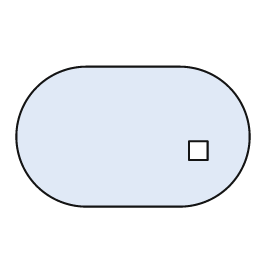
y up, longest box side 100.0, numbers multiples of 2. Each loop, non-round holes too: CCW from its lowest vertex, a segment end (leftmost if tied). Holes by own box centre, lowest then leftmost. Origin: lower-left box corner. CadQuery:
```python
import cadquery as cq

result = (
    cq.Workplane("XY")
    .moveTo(30.0, 0.0)
    .lineTo(70.0, 0.0)
    .threePointArc((100.0, 30.0), (70.0, 60.0))
    .lineTo(30.0, 60.0)
    .threePointArc((0.0, 30.0), (30.0, 0.0))
    .close()
    .moveTo(74.0, 20.0)
    .lineTo(82.0, 20.0)
    .lineTo(82.0, 28.0)
    .lineTo(74.0, 28.0)
    .close()
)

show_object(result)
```